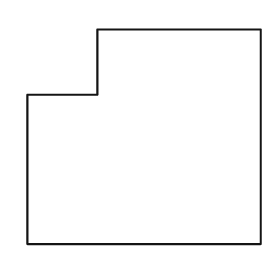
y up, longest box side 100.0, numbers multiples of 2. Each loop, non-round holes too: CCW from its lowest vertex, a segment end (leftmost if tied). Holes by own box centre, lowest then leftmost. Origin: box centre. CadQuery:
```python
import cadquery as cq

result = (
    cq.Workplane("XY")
    .moveTo(-50.0, -46.0)
    .lineTo(50.0, -46.0)
    .lineTo(50.0, 46.0)
    .lineTo(-20.0, 46.0)
    .lineTo(-20.0, 18.0)
    .lineTo(-50.0, 18.0)
    .close()
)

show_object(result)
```